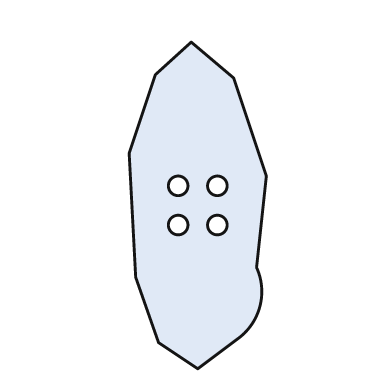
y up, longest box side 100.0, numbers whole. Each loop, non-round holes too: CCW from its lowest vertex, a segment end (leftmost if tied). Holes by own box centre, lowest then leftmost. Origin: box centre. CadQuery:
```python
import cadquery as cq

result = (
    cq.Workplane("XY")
    .moveTo(0.0, -50.0)
    .lineTo(12.0, -41.0)
    .threePointArc((19.0, -31.0), (18.0, -19.0))
    .lineTo(21.0, 9.0)
    .lineTo(11.0, 39.0)
    .lineTo(-2.0, 50.0)
    .lineTo(-13.0, 40.0)
    .lineTo(-21.0, 16.0)
    .lineTo(-19.0, -22.0)
    .lineTo(-12.0, -42.0)
    .close()
    .moveTo(-6.0, -6.0)
    .circle(3.0)
    .moveTo(6.0, -6.0)
    .circle(3.0)
    .moveTo(-6.0, 6.0)
    .circle(3.0)
    .moveTo(6.0, 6.0)
    .circle(3.0)
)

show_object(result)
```